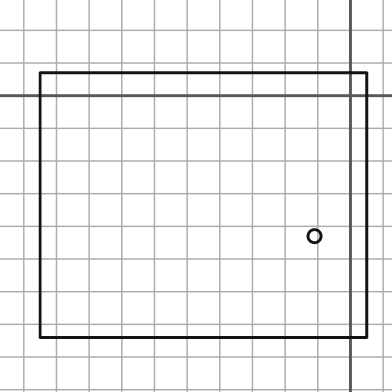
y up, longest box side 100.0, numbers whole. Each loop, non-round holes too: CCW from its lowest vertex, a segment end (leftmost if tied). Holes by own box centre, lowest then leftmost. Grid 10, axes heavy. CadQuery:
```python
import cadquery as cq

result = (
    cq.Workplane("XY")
    .moveTo(-95.0, -74.0)
    .lineTo(5.0, -74.0)
    .lineTo(5.0, 7.0)
    .lineTo(-95.0, 7.0)
    .close()
    .moveTo(-11.0, -43.0)
    .circle(2.0)
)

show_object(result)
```